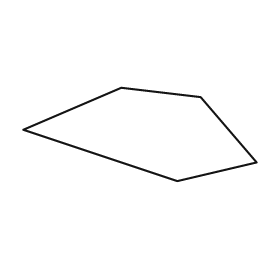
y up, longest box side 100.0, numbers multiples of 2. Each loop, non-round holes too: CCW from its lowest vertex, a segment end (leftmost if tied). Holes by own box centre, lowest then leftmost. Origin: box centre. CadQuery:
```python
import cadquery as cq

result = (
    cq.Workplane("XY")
    .moveTo(16.0, -20.0)
    .lineTo(50.0, -12.0)
    .lineTo(26.0, 16.0)
    .lineTo(-8.0, 20.0)
    .lineTo(-50.0, 2.0)
    .close()
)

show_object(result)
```